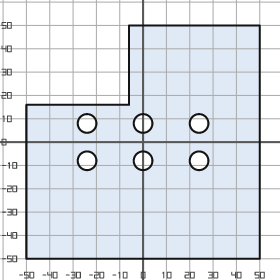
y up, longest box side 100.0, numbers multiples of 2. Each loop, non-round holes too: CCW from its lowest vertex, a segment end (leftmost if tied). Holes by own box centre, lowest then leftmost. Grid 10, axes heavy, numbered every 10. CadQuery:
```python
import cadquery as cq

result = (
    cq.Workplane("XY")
    .moveTo(-50.0, -50.0)
    .lineTo(50.0, -50.0)
    .lineTo(50.0, 50.0)
    .lineTo(-6.0, 50.0)
    .lineTo(-6.0, 16.0)
    .lineTo(-50.0, 16.0)
    .close()
    .moveTo(-24.0, -8.0)
    .circle(4.0)
    .moveTo(0.0, -8.0)
    .circle(4.0)
    .moveTo(24.0, -8.0)
    .circle(4.0)
    .moveTo(-24.0, 8.0)
    .circle(4.0)
    .moveTo(0.0, 8.0)
    .circle(4.0)
    .moveTo(24.0, 8.0)
    .circle(4.0)
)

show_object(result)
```